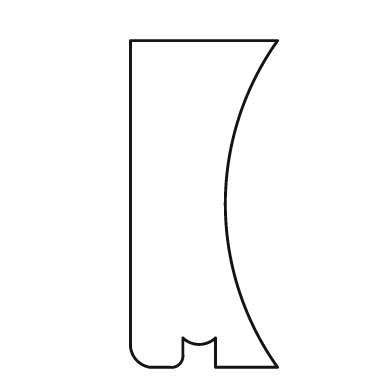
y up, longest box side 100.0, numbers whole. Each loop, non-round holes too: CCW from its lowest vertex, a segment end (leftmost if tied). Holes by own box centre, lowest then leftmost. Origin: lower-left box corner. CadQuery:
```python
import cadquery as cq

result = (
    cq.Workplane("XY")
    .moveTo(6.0, 0.0)
    .lineTo(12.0, 0.0)
    .threePointArc((15.0, 1.0), (16.0, 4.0))
    .lineTo(16.0, 9.0)
    .threePointArc((21.0, 7.0), (26.0, 9.0))
    .lineTo(26.0, 0.0)
    .lineTo(45.0, 0.0)
    .threePointArc((29.0, 50.0), (45.0, 100.0))
    .lineTo(0.0, 100.0)
    .lineTo(0.0, 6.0)
    .threePointArc((2.0, 2.0), (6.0, 0.0))
    .close()
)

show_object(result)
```